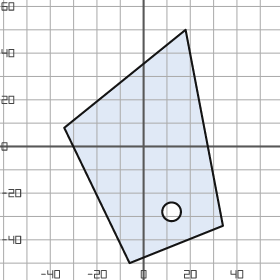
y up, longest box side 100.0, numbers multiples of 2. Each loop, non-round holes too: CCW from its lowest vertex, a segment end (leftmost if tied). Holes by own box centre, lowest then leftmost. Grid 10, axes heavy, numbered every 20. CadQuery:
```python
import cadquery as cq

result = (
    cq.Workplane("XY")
    .moveTo(-6.0, -50.0)
    .lineTo(34.0, -34.0)
    .lineTo(18.0, 50.0)
    .lineTo(-34.0, 8.0)
    .close()
    .moveTo(12.0, -28.0)
    .circle(4.0)
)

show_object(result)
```